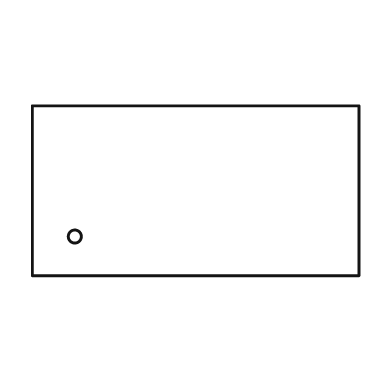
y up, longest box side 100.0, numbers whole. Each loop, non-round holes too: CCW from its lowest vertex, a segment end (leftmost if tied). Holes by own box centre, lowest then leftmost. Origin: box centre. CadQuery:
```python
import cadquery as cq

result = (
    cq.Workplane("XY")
    .moveTo(-50.0, -26.0)
    .lineTo(50.0, -26.0)
    .lineTo(50.0, 26.0)
    .lineTo(-50.0, 26.0)
    .close()
    .moveTo(-37.0, -14.0)
    .circle(2.0)
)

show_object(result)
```